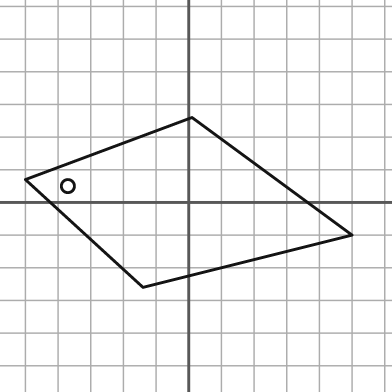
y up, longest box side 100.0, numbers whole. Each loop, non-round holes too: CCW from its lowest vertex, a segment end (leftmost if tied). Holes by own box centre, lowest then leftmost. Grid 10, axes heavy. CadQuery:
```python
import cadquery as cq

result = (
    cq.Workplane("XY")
    .moveTo(-14.0, -26.0)
    .lineTo(50.0, -10.0)
    .lineTo(1.0, 26.0)
    .lineTo(-50.0, 7.0)
    .close()
    .moveTo(-37.0, 5.0)
    .circle(2.0)
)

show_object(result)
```